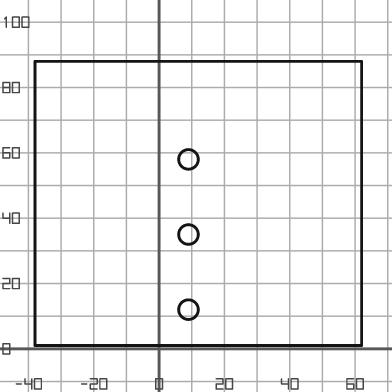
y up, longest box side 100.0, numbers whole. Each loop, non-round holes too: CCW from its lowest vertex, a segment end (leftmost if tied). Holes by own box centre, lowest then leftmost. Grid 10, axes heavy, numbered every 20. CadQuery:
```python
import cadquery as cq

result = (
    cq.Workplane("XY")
    .moveTo(-38.0, 1.0)
    .lineTo(62.0, 1.0)
    .lineTo(62.0, 88.0)
    .lineTo(-38.0, 88.0)
    .close()
    .moveTo(9.0, 12.0)
    .circle(3.0)
    .moveTo(9.0, 35.0)
    .circle(3.0)
    .moveTo(9.0, 58.0)
    .circle(3.0)
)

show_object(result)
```